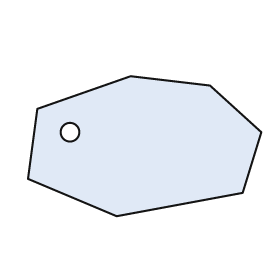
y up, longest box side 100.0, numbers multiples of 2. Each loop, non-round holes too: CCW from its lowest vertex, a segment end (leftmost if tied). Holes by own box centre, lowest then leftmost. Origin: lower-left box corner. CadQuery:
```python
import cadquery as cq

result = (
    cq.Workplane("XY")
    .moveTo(38.0, 0.0)
    .lineTo(92.0, 10.0)
    .lineTo(100.0, 36.0)
    .lineTo(78.0, 56.0)
    .lineTo(44.0, 60.0)
    .lineTo(4.0, 46.0)
    .lineTo(0.0, 16.0)
    .close()
    .moveTo(18.0, 36.0)
    .circle(4.0)
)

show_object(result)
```